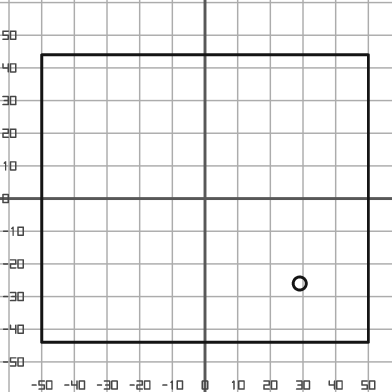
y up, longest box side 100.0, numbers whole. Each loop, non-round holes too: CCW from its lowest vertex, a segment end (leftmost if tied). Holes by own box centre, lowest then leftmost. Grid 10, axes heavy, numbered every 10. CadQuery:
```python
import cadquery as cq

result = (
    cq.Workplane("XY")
    .moveTo(-50.0, -44.0)
    .lineTo(50.0, -44.0)
    .lineTo(50.0, 44.0)
    .lineTo(-50.0, 44.0)
    .close()
    .moveTo(29.0, -26.0)
    .circle(2.0)
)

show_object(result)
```